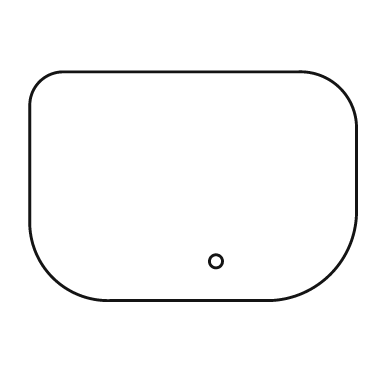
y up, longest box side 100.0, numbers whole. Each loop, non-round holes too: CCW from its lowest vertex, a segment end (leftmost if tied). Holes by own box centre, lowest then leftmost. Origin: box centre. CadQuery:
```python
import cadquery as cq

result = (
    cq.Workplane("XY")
    .moveTo(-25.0, -35.0)
    .lineTo(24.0, -35.0)
    .threePointArc((42.0, -27.0), (50.0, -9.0))
    .lineTo(50.0, 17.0)
    .threePointArc((45.0, 30.0), (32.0, 35.0))
    .lineTo(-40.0, 35.0)
    .threePointArc((-47.0, 32.0), (-50.0, 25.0))
    .lineTo(-50.0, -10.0)
    .threePointArc((-43.0, -28.0), (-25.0, -35.0))
    .close()
    .moveTo(7.0, -23.0)
    .circle(2.0)
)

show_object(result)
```